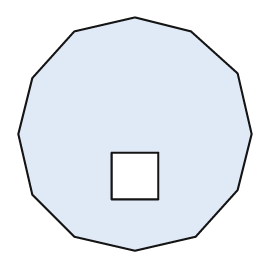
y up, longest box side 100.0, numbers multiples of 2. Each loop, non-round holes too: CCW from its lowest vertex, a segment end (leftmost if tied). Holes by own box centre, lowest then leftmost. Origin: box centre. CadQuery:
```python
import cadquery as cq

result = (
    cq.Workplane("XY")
    .moveTo(0.0, -50.0)
    .lineTo(26.0, -44.0)
    .lineTo(44.0, -24.0)
    .lineTo(50.0, 0.0)
    .lineTo(44.0, 26.0)
    .lineTo(24.0, 44.0)
    .lineTo(0.0, 50.0)
    .lineTo(-26.0, 44.0)
    .lineTo(-44.0, 24.0)
    .lineTo(-50.0, 0.0)
    .lineTo(-44.0, -26.0)
    .lineTo(-26.0, -44.0)
    .close()
    .moveTo(-10.0, -28.0)
    .lineTo(10.0, -28.0)
    .lineTo(10.0, -8.0)
    .lineTo(-10.0, -8.0)
    .close()
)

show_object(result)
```